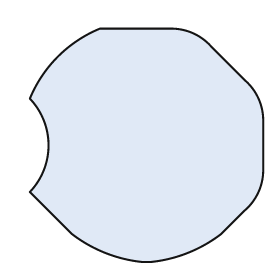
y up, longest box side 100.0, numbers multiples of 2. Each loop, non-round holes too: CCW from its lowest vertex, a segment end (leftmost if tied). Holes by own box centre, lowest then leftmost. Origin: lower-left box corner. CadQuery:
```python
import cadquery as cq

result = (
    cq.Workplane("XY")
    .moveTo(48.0, 0.0)
    .lineTo(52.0, 0.0)
    .threePointArc((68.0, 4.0), (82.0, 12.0))
    .lineTo(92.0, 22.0)
    .threePointArc((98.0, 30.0), (100.0, 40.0))
    .lineTo(100.0, 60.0)
    .threePointArc((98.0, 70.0), (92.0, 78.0))
    .lineTo(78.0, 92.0)
    .threePointArc((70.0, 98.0), (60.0, 100.0))
    .lineTo(30.0, 100.0)
    .threePointArc((12.0, 88.0), (0.0, 70.0))
    .threePointArc((8.0, 50.0), (0.0, 30.0))
    .lineTo(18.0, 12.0)
    .threePointArc((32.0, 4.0), (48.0, 0.0))
    .close()
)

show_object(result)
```